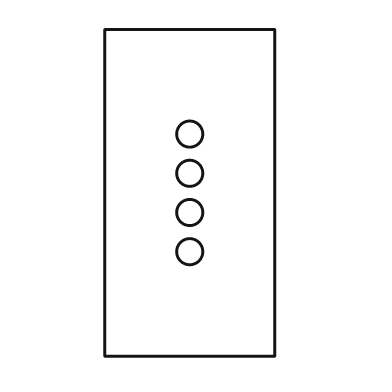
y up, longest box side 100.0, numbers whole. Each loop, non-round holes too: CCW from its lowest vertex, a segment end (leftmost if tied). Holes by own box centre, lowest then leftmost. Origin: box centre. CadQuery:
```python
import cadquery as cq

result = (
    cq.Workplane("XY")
    .moveTo(-26.0, -50.0)
    .lineTo(26.0, -50.0)
    .lineTo(26.0, 50.0)
    .lineTo(-26.0, 50.0)
    .close()
    .moveTo(0.0, -18.0)
    .circle(4.0)
    .moveTo(0.0, -6.0)
    .circle(4.0)
    .moveTo(0.0, 6.0)
    .circle(4.0)
    .moveTo(0.0, 18.0)
    .circle(4.0)
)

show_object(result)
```